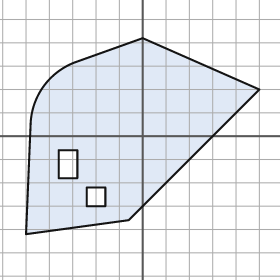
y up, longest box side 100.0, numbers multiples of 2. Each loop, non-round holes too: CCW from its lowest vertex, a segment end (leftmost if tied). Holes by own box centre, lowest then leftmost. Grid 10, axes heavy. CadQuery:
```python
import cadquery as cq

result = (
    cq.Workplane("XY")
    .moveTo(-50.0, -42.0)
    .lineTo(-6.0, -36.0)
    .lineTo(50.0, 20.0)
    .lineTo(0.0, 42.0)
    .lineTo(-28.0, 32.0)
    .threePointArc((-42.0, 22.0), (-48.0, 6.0))
    .close()
    .moveTo(-24.0, -30.0)
    .lineTo(-16.0, -30.0)
    .lineTo(-16.0, -22.0)
    .lineTo(-24.0, -22.0)
    .close()
    .moveTo(-36.0, -18.0)
    .lineTo(-28.0, -18.0)
    .lineTo(-28.0, -6.0)
    .lineTo(-36.0, -6.0)
    .close()
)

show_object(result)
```